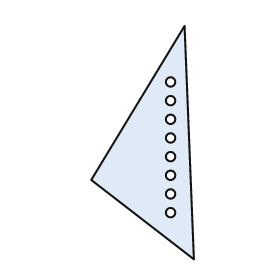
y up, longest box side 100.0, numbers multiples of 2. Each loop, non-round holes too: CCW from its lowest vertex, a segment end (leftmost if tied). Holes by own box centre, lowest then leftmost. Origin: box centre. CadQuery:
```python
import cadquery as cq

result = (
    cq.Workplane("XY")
    .moveTo(22.0, -50.0)
    .lineTo(18.0, 50.0)
    .lineTo(-22.0, -16.0)
    .close()
    .moveTo(12.0, -30.0)
    .circle(2.0)
    .moveTo(12.0, -22.0)
    .circle(2.0)
    .moveTo(12.0, -14.0)
    .circle(2.0)
    .moveTo(12.0, -6.0)
    .circle(2.0)
    .moveTo(12.0, 2.0)
    .circle(2.0)
    .moveTo(12.0, 10.0)
    .circle(2.0)
    .moveTo(12.0, 18.0)
    .circle(2.0)
    .moveTo(12.0, 26.0)
    .circle(2.0)
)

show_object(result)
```